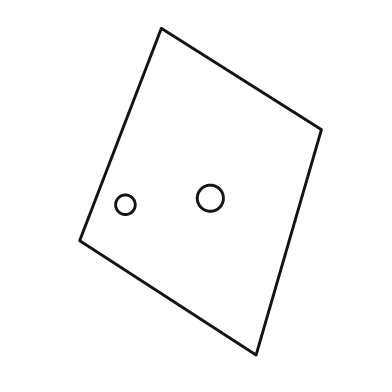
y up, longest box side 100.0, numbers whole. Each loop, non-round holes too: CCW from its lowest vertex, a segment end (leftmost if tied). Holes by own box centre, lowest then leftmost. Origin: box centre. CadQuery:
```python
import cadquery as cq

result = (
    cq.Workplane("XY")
    .moveTo(17.0, -50.0)
    .lineTo(37.0, 19.0)
    .lineTo(-12.0, 50.0)
    .lineTo(-37.0, -15.0)
    .close()
    .moveTo(-23.0, -4.0)
    .circle(3.0)
    .moveTo(3.0, -2.0)
    .circle(4.0)
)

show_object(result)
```